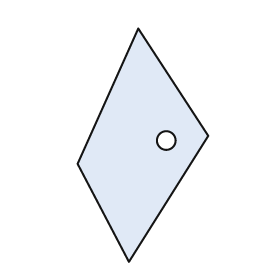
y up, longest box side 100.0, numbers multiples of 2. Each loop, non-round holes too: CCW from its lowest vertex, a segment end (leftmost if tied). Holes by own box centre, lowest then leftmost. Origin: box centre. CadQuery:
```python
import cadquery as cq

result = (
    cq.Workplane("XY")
    .moveTo(-6.0, -50.0)
    .lineTo(28.0, 4.0)
    .lineTo(-2.0, 50.0)
    .lineTo(-28.0, -8.0)
    .close()
    .moveTo(10.0, 2.0)
    .circle(4.0)
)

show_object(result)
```